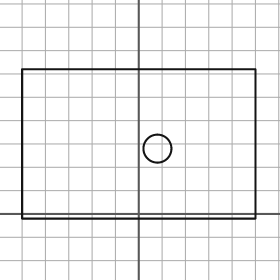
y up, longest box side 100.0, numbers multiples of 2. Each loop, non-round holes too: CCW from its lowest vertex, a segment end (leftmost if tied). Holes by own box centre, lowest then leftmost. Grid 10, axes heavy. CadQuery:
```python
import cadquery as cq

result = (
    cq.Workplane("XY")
    .moveTo(-50.0, -2.0)
    .lineTo(50.0, -2.0)
    .lineTo(50.0, 62.0)
    .lineTo(-50.0, 62.0)
    .close()
    .moveTo(8.0, 28.0)
    .circle(6.0)
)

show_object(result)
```